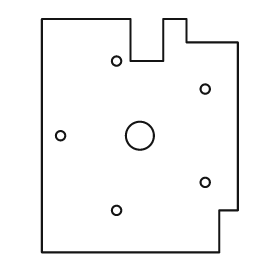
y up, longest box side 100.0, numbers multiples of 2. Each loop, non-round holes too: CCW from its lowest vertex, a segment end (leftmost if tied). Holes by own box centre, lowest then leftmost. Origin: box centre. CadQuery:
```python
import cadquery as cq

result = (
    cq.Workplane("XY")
    .moveTo(-42.0, -50.0)
    .lineTo(34.0, -50.0)
    .lineTo(34.0, -32.0)
    .lineTo(42.0, -32.0)
    .lineTo(42.0, 40.0)
    .lineTo(20.0, 40.0)
    .lineTo(20.0, 50.0)
    .lineTo(10.0, 50.0)
    .lineTo(10.0, 32.0)
    .lineTo(-4.0, 32.0)
    .lineTo(-4.0, 50.0)
    .lineTo(-42.0, 50.0)
    .close()
    .moveTo(-10.0, -32.0)
    .circle(2.0)
    .moveTo(28.0, -20.0)
    .circle(2.0)
    .moveTo(-34.0, 0.0)
    .circle(2.0)
    .moveTo(0.0, 0.0)
    .circle(6.0)
    .moveTo(28.0, 20.0)
    .circle(2.0)
    .moveTo(-10.0, 32.0)
    .circle(2.0)
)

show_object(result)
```